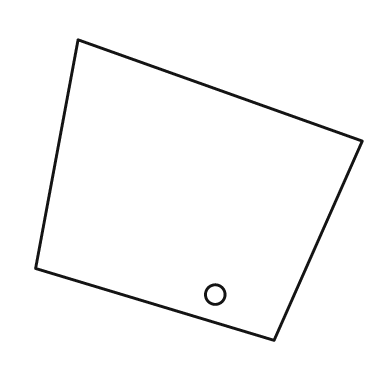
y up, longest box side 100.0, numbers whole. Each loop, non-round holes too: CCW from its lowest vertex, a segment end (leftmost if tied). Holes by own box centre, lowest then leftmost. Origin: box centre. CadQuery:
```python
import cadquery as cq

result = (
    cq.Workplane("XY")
    .moveTo(23.0, -46.0)
    .lineTo(50.0, 15.0)
    .lineTo(-37.0, 46.0)
    .lineTo(-50.0, -24.0)
    .close()
    .moveTo(5.0, -32.0)
    .circle(3.0)
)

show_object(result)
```